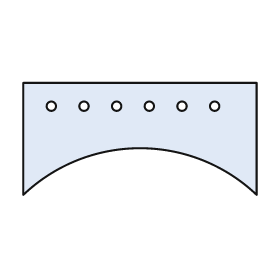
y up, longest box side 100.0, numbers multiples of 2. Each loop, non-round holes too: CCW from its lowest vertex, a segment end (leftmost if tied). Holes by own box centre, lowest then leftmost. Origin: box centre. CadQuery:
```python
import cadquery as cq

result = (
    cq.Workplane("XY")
    .moveTo(-50.0, -24.0)
    .threePointArc((0.0, -4.0), (50.0, -24.0))
    .lineTo(50.0, 24.0)
    .lineTo(-50.0, 24.0)
    .close()
    .moveTo(-38.0, 14.0)
    .circle(2.0)
    .moveTo(-24.0, 14.0)
    .circle(2.0)
    .moveTo(-10.0, 14.0)
    .circle(2.0)
    .moveTo(4.0, 14.0)
    .circle(2.0)
    .moveTo(18.0, 14.0)
    .circle(2.0)
    .moveTo(32.0, 14.0)
    .circle(2.0)
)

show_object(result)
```